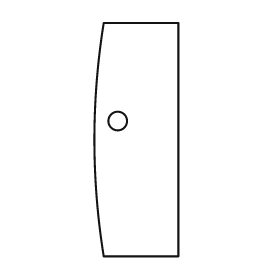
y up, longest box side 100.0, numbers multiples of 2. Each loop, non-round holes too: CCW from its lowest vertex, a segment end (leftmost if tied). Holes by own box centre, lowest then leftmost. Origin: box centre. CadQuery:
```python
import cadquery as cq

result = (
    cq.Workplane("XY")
    .moveTo(-14.0, -50.0)
    .lineTo(18.0, -50.0)
    .lineTo(18.0, 50.0)
    .lineTo(-14.0, 50.0)
    .threePointArc((-18.0, 0.0), (-14.0, -50.0))
    .close()
    .moveTo(-8.0, 8.0)
    .circle(4.0)
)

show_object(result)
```